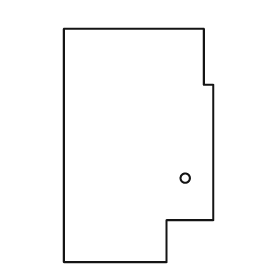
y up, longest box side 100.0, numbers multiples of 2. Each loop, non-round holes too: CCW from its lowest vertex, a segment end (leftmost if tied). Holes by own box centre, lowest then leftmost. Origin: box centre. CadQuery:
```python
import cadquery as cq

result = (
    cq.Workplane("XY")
    .moveTo(-32.0, -50.0)
    .lineTo(12.0, -50.0)
    .lineTo(12.0, -32.0)
    .lineTo(32.0, -32.0)
    .lineTo(32.0, 26.0)
    .lineTo(28.0, 26.0)
    .lineTo(28.0, 50.0)
    .lineTo(-32.0, 50.0)
    .close()
    .moveTo(20.0, -14.0)
    .circle(2.0)
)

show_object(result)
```